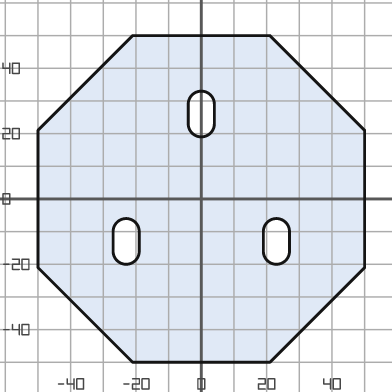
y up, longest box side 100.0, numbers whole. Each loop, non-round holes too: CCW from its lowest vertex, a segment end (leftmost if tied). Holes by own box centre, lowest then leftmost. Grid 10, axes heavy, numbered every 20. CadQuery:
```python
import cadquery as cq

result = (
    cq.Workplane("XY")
    .moveTo(-21.0, -50.0)
    .lineTo(21.0, -50.0)
    .lineTo(50.0, -21.0)
    .lineTo(50.0, 21.0)
    .lineTo(21.0, 50.0)
    .lineTo(-21.0, 50.0)
    .lineTo(-50.0, 21.0)
    .lineTo(-50.0, -21.0)
    .close()
    .moveTo(-27.0, -16.0)
    .threePointArc((-23.0, -20.0), (-19.0, -16.0))
    .lineTo(-19.0, -10.0)
    .threePointArc((-23.0, -6.0), (-27.0, -10.0))
    .close()
    .moveTo(19.0, -16.0)
    .threePointArc((23.0, -20.0), (27.0, -16.0))
    .lineTo(27.0, -10.0)
    .threePointArc((23.0, -6.0), (19.0, -10.0))
    .close()
    .moveTo(-4.0, 23.0)
    .threePointArc((0.0, 19.0), (4.0, 23.0))
    .lineTo(4.0, 29.0)
    .threePointArc((0.0, 33.0), (-4.0, 29.0))
    .close()
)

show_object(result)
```